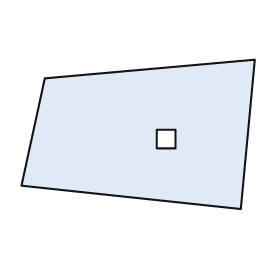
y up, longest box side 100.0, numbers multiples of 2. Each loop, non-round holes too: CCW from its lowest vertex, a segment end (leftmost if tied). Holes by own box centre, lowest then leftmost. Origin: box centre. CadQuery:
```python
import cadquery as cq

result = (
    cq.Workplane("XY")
    .moveTo(44.0, -32.0)
    .lineTo(50.0, 32.0)
    .lineTo(-40.0, 24.0)
    .lineTo(-50.0, -22.0)
    .close()
    .moveTo(8.0, -6.0)
    .lineTo(16.0, -6.0)
    .lineTo(16.0, 2.0)
    .lineTo(8.0, 2.0)
    .close()
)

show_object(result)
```